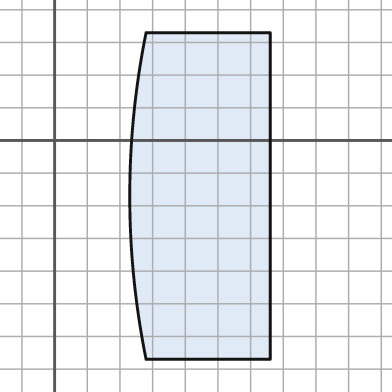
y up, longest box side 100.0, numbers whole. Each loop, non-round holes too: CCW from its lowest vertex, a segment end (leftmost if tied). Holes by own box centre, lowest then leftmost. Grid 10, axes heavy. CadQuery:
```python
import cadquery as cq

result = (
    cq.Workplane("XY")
    .moveTo(28.0, -67.0)
    .lineTo(66.0, -67.0)
    .lineTo(66.0, 33.0)
    .lineTo(28.0, 33.0)
    .threePointArc((23.0, -17.0), (28.0, -67.0))
    .close()
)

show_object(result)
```